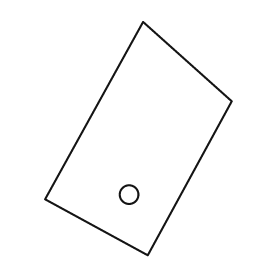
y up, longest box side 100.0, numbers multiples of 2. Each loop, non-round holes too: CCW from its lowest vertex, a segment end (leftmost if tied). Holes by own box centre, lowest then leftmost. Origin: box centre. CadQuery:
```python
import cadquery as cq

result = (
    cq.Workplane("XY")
    .moveTo(4.0, -50.0)
    .lineTo(40.0, 16.0)
    .lineTo(2.0, 50.0)
    .lineTo(-40.0, -26.0)
    .close()
    .moveTo(-4.0, -24.0)
    .circle(4.0)
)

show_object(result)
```